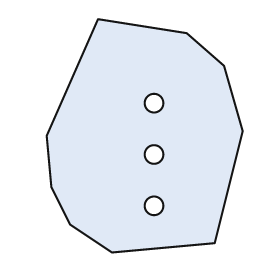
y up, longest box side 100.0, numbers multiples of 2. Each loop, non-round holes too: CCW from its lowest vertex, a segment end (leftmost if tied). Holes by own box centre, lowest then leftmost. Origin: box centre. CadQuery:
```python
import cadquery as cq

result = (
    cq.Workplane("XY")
    .moveTo(-14.0, -50.0)
    .lineTo(30.0, -46.0)
    .lineTo(42.0, 2.0)
    .lineTo(34.0, 30.0)
    .lineTo(18.0, 44.0)
    .lineTo(-20.0, 50.0)
    .lineTo(-42.0, 0.0)
    .lineTo(-40.0, -22.0)
    .lineTo(-32.0, -38.0)
    .close()
    .moveTo(4.0, -30.0)
    .circle(4.0)
    .moveTo(4.0, -8.0)
    .circle(4.0)
    .moveTo(4.0, 14.0)
    .circle(4.0)
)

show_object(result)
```